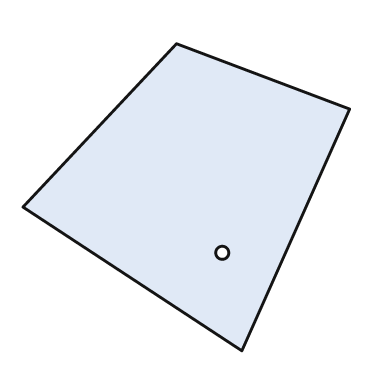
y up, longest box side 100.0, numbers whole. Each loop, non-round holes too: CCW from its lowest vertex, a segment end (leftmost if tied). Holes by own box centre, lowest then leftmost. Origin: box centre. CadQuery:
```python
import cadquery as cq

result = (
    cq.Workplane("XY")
    .moveTo(17.0, -47.0)
    .lineTo(50.0, 27.0)
    .lineTo(-3.0, 47.0)
    .lineTo(-50.0, -3.0)
    .close()
    .moveTo(11.0, -17.0)
    .circle(2.0)
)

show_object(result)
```